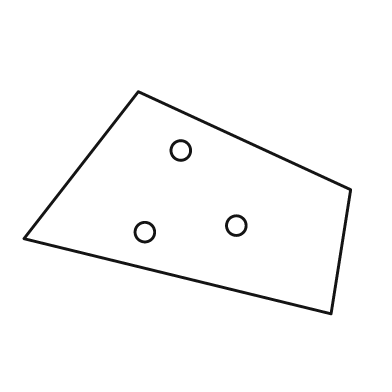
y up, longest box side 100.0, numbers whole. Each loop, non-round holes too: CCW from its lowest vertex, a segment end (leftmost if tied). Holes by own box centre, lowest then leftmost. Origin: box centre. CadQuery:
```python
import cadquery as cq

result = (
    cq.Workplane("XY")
    .moveTo(44.0, -34.0)
    .lineTo(50.0, 4.0)
    .lineTo(-15.0, 34.0)
    .lineTo(-50.0, -11.0)
    .close()
    .moveTo(-13.0, -9.0)
    .circle(3.0)
    .moveTo(15.0, -7.0)
    .circle(3.0)
    .moveTo(-2.0, 16.0)
    .circle(3.0)
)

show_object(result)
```